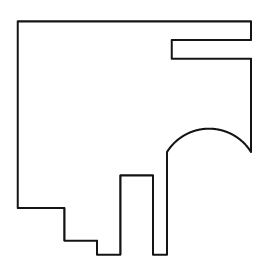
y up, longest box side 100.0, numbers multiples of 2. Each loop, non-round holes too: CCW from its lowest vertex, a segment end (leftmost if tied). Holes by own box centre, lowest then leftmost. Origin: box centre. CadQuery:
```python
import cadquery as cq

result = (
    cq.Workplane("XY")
    .moveTo(-16.0, -50.0)
    .lineTo(-6.0, -50.0)
    .lineTo(-6.0, -16.0)
    .lineTo(8.0, -16.0)
    .lineTo(8.0, -50.0)
    .lineTo(14.0, -50.0)
    .lineTo(14.0, -6.0)
    .threePointArc((32.0, 4.0), (50.0, -6.0))
    .lineTo(50.0, 34.0)
    .lineTo(16.0, 34.0)
    .lineTo(16.0, 42.0)
    .lineTo(50.0, 42.0)
    .lineTo(50.0, 50.0)
    .lineTo(-50.0, 50.0)
    .lineTo(-50.0, -30.0)
    .lineTo(-30.0, -30.0)
    .lineTo(-30.0, -44.0)
    .lineTo(-16.0, -44.0)
    .close()
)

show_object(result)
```